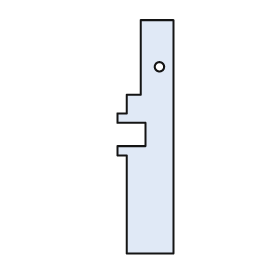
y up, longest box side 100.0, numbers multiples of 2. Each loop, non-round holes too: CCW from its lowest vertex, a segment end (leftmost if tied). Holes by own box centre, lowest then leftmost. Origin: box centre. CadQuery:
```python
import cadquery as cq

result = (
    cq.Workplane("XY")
    .moveTo(-8.0, -50.0)
    .lineTo(12.0, -50.0)
    .lineTo(12.0, 50.0)
    .lineTo(-2.0, 50.0)
    .lineTo(-2.0, 18.0)
    .lineTo(-8.0, 18.0)
    .lineTo(-8.0, 10.0)
    .lineTo(-12.0, 10.0)
    .lineTo(-12.0, 6.0)
    .lineTo(0.0, 6.0)
    .lineTo(0.0, -4.0)
    .lineTo(-12.0, -4.0)
    .lineTo(-12.0, -8.0)
    .lineTo(-8.0, -8.0)
    .close()
    .moveTo(6.0, 30.0)
    .circle(2.0)
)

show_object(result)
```